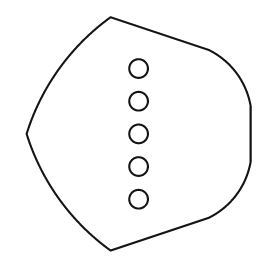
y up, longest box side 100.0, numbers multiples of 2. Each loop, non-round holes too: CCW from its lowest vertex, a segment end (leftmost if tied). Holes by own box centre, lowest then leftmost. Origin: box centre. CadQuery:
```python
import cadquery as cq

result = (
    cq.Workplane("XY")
    .moveTo(-12.0, -50.0)
    .lineTo(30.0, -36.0)
    .threePointArc((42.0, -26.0), (48.0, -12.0))
    .lineTo(48.0, 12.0)
    .threePointArc((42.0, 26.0), (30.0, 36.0))
    .lineTo(-12.0, 50.0)
    .threePointArc((-34.0, 28.0), (-48.0, 0.0))
    .threePointArc((-34.0, -28.0), (-12.0, -50.0))
    .close()
    .moveTo(0.0, -28.0)
    .circle(4.0)
    .moveTo(0.0, -14.0)
    .circle(4.0)
    .moveTo(0.0, 0.0)
    .circle(4.0)
    .moveTo(0.0, 14.0)
    .circle(4.0)
    .moveTo(0.0, 28.0)
    .circle(4.0)
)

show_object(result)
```